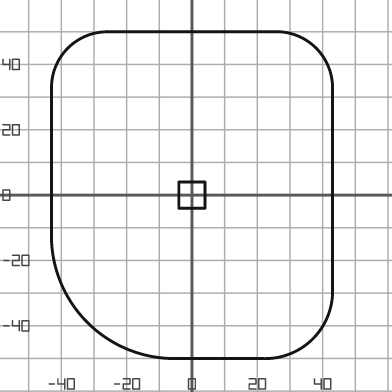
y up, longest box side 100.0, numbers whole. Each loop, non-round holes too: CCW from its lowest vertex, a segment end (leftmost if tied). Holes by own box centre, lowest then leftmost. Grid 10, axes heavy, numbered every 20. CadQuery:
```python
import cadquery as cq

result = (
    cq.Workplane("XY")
    .moveTo(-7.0, -50.0)
    .lineTo(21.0, -50.0)
    .threePointArc((37.0, -44.0), (43.0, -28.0))
    .lineTo(43.0, 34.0)
    .threePointArc((38.0, 45.0), (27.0, 50.0))
    .lineTo(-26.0, 50.0)
    .threePointArc((-38.0, 45.0), (-43.0, 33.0))
    .lineTo(-43.0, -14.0)
    .threePointArc((-32.0, -39.0), (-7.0, -50.0))
    .close()
    .moveTo(-4.0, -4.0)
    .lineTo(4.0, -4.0)
    .lineTo(4.0, 4.0)
    .lineTo(-4.0, 4.0)
    .close()
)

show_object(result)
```